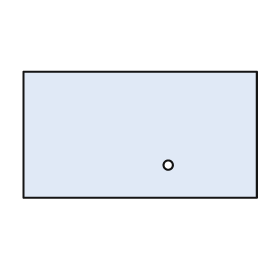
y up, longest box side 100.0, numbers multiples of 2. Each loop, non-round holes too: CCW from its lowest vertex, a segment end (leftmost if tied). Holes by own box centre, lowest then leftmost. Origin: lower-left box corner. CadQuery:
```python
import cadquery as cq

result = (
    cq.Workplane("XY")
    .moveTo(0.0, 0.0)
    .lineTo(100.0, 0.0)
    .lineTo(100.0, 54.0)
    .lineTo(0.0, 54.0)
    .close()
    .moveTo(62.0, 14.0)
    .circle(2.0)
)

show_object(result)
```